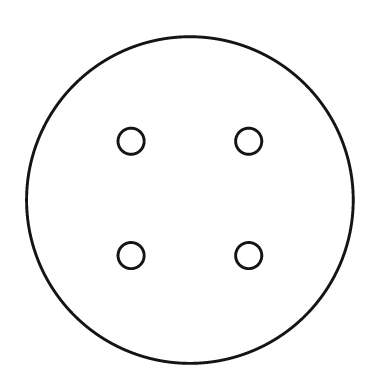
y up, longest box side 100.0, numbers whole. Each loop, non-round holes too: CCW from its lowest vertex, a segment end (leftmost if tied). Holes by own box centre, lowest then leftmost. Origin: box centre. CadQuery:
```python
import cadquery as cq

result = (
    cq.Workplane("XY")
    .moveTo(0.0, 0.0)
    .circle(50.0)
    .moveTo(-18.0, -17.0)
    .circle(4.0)
    .moveTo(18.0, -17.0)
    .circle(4.0)
    .moveTo(-18.0, 18.0)
    .circle(4.0)
    .moveTo(18.0, 18.0)
    .circle(4.0)
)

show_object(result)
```